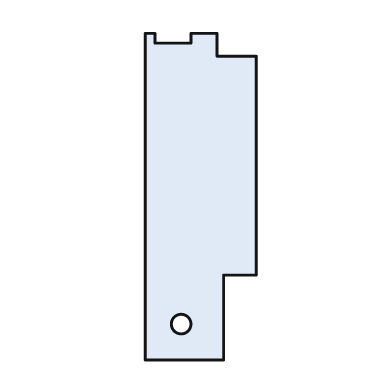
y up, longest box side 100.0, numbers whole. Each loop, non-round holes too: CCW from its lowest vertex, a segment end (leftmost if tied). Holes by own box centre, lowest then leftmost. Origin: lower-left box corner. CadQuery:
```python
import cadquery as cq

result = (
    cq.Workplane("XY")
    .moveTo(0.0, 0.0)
    .lineTo(24.0, 0.0)
    .lineTo(24.0, 26.0)
    .lineTo(34.0, 26.0)
    .lineTo(34.0, 93.0)
    .lineTo(22.0, 93.0)
    .lineTo(22.0, 100.0)
    .lineTo(14.0, 100.0)
    .lineTo(14.0, 97.0)
    .lineTo(3.0, 97.0)
    .lineTo(3.0, 100.0)
    .lineTo(0.0, 100.0)
    .close()
    .moveTo(11.0, 11.0)
    .circle(3.0)
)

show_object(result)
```